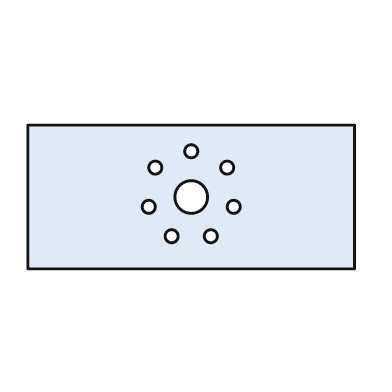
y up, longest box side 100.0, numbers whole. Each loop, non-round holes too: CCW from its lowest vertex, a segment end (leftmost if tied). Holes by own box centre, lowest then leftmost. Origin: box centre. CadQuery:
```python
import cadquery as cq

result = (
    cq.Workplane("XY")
    .moveTo(-50.0, -22.0)
    .lineTo(50.0, -22.0)
    .lineTo(50.0, 22.0)
    .lineTo(-50.0, 22.0)
    .close()
    .moveTo(-6.0, -12.0)
    .circle(2.0)
    .moveTo(6.0, -12.0)
    .circle(2.0)
    .moveTo(-13.0, -3.0)
    .circle(2.0)
    .moveTo(13.0, -3.0)
    .circle(2.0)
    .moveTo(0.0, 0.0)
    .circle(5.0)
    .moveTo(-11.0, 9.0)
    .circle(2.0)
    .moveTo(11.0, 9.0)
    .circle(2.0)
    .moveTo(0.0, 14.0)
    .circle(2.0)
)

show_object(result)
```